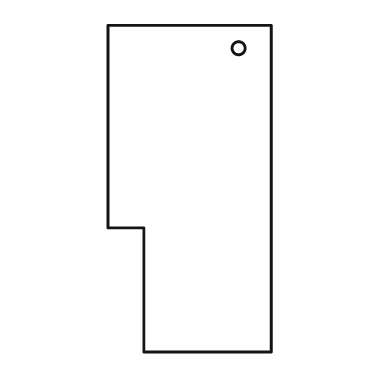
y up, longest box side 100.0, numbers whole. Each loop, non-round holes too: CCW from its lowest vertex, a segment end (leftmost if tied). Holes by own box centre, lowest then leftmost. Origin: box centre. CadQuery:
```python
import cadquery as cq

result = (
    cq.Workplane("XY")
    .moveTo(-14.0, -50.0)
    .lineTo(25.0, -50.0)
    .lineTo(25.0, 50.0)
    .lineTo(-25.0, 50.0)
    .lineTo(-25.0, -12.0)
    .lineTo(-14.0, -12.0)
    .close()
    .moveTo(15.0, 43.0)
    .circle(2.0)
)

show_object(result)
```